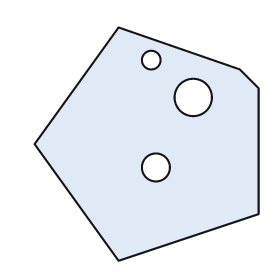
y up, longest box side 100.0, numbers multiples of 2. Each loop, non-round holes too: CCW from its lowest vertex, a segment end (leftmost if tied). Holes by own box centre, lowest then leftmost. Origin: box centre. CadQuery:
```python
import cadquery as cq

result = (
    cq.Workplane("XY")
    .moveTo(-12.0, -50.0)
    .lineTo(48.0, -30.0)
    .lineTo(48.0, 24.0)
    .lineTo(40.0, 32.0)
    .lineTo(-12.0, 50.0)
    .lineTo(-48.0, 0.0)
    .close()
    .moveTo(4.0, -10.0)
    .circle(6.0)
    .moveTo(20.0, 20.0)
    .circle(8.0)
    .moveTo(2.0, 36.0)
    .circle(4.0)
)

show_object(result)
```